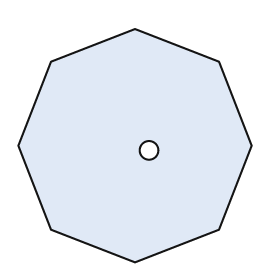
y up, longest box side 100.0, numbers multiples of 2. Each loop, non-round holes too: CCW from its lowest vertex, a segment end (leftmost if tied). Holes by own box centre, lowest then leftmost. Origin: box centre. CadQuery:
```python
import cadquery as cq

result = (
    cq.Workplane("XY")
    .moveTo(0.0, -50.0)
    .lineTo(36.0, -36.0)
    .lineTo(50.0, 0.0)
    .lineTo(36.0, 36.0)
    .lineTo(0.0, 50.0)
    .lineTo(-36.0, 36.0)
    .lineTo(-50.0, 0.0)
    .lineTo(-36.0, -36.0)
    .close()
    .moveTo(6.0, -2.0)
    .circle(4.0)
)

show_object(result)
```